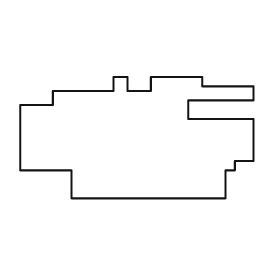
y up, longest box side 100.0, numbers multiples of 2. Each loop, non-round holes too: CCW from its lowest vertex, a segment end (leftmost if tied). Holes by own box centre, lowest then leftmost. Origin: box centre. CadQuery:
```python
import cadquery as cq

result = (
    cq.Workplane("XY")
    .moveTo(-28.0, -26.0)
    .lineTo(38.0, -26.0)
    .lineTo(38.0, -14.0)
    .lineTo(42.0, -14.0)
    .lineTo(42.0, -10.0)
    .lineTo(50.0, -10.0)
    .lineTo(50.0, 8.0)
    .lineTo(22.0, 8.0)
    .lineTo(22.0, 16.0)
    .lineTo(50.0, 16.0)
    .lineTo(50.0, 22.0)
    .lineTo(28.0, 22.0)
    .lineTo(28.0, 26.0)
    .lineTo(6.0, 26.0)
    .lineTo(6.0, 20.0)
    .lineTo(-4.0, 20.0)
    .lineTo(-4.0, 26.0)
    .lineTo(-10.0, 26.0)
    .lineTo(-10.0, 20.0)
    .lineTo(-36.0, 20.0)
    .lineTo(-36.0, 14.0)
    .lineTo(-50.0, 14.0)
    .lineTo(-50.0, -14.0)
    .lineTo(-28.0, -14.0)
    .close()
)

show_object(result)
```